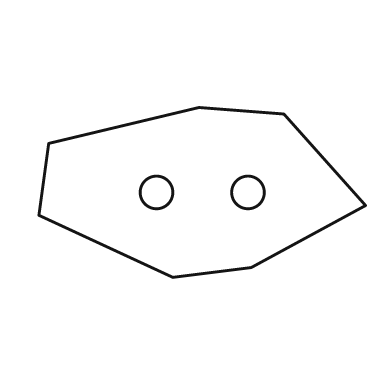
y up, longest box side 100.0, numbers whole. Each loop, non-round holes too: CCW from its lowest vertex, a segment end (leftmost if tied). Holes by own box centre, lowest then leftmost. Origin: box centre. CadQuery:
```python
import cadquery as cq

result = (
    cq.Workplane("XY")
    .moveTo(-9.0, -26.0)
    .lineTo(15.0, -23.0)
    .lineTo(50.0, -4.0)
    .lineTo(25.0, 24.0)
    .lineTo(-1.0, 26.0)
    .lineTo(-47.0, 15.0)
    .lineTo(-50.0, -7.0)
    .close()
    .moveTo(-14.0, 0.0)
    .circle(5.0)
    .moveTo(14.0, 0.0)
    .circle(5.0)
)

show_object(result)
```